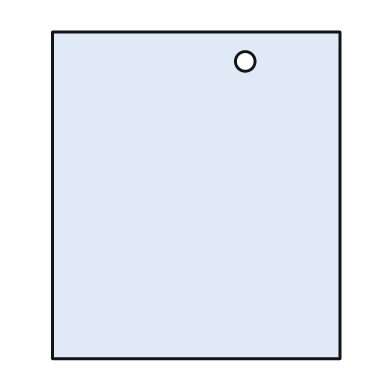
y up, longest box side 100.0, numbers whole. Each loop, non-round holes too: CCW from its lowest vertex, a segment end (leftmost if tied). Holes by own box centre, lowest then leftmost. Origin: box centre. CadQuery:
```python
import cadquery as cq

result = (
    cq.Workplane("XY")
    .moveTo(-44.0, -50.0)
    .lineTo(44.0, -50.0)
    .lineTo(44.0, 50.0)
    .lineTo(-44.0, 50.0)
    .close()
    .moveTo(15.0, 41.0)
    .circle(3.0)
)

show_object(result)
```